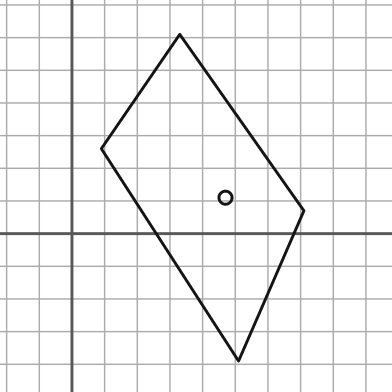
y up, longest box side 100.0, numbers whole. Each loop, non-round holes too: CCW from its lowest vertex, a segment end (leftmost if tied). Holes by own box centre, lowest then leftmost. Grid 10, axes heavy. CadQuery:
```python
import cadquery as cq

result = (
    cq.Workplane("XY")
    .moveTo(51.0, -39.0)
    .lineTo(71.0, 7.0)
    .lineTo(33.0, 61.0)
    .lineTo(9.0, 26.0)
    .close()
    .moveTo(47.0, 11.0)
    .circle(2.0)
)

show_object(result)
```